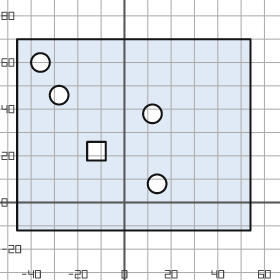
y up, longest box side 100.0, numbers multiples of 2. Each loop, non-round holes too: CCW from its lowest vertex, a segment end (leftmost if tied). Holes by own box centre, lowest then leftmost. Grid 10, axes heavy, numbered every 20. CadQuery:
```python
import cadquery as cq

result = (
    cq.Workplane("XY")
    .moveTo(-46.0, -12.0)
    .lineTo(54.0, -12.0)
    .lineTo(54.0, 70.0)
    .lineTo(-46.0, 70.0)
    .close()
    .moveTo(14.0, 8.0)
    .circle(4.0)
    .moveTo(-16.0, 18.0)
    .lineTo(-8.0, 18.0)
    .lineTo(-8.0, 26.0)
    .lineTo(-16.0, 26.0)
    .close()
    .moveTo(12.0, 38.0)
    .circle(4.0)
    .moveTo(-28.0, 46.0)
    .circle(4.0)
    .moveTo(-36.0, 60.0)
    .circle(4.0)
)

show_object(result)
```